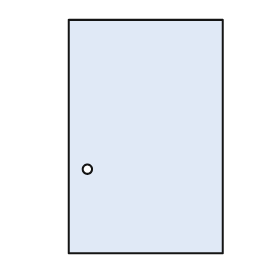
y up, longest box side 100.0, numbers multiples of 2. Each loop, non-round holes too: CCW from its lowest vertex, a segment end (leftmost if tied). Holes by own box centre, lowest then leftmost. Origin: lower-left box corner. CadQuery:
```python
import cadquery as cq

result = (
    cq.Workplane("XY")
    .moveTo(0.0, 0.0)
    .lineTo(66.0, 0.0)
    .lineTo(66.0, 100.0)
    .lineTo(0.0, 100.0)
    .close()
    .moveTo(8.0, 36.0)
    .circle(2.0)
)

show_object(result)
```